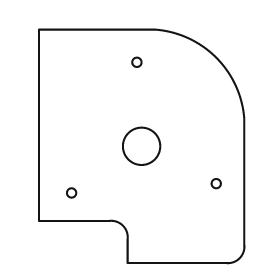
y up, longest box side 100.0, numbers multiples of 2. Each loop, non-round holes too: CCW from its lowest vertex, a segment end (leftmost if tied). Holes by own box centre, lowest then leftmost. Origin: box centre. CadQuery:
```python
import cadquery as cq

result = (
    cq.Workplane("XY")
    .moveTo(-6.0, -50.0)
    .lineTo(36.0, -50.0)
    .threePointArc((42.0, -48.0), (44.0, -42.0))
    .lineTo(44.0, 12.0)
    .threePointArc((32.0, 38.0), (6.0, 50.0))
    .lineTo(-44.0, 50.0)
    .lineTo(-44.0, -32.0)
    .lineTo(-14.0, -32.0)
    .threePointArc((-8.0, -34.0), (-6.0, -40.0))
    .close()
    .moveTo(-30.0, -20.0)
    .circle(2.0)
    .moveTo(32.0, -16.0)
    .circle(2.0)
    .moveTo(0.0, 0.0)
    .circle(8.0)
    .moveTo(-2.0, 36.0)
    .circle(2.0)
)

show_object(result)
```